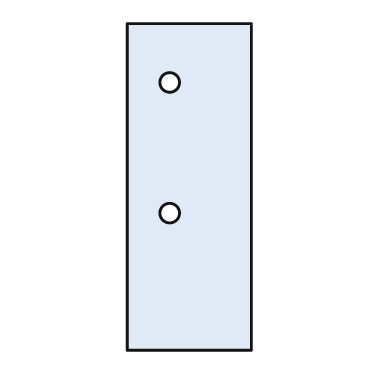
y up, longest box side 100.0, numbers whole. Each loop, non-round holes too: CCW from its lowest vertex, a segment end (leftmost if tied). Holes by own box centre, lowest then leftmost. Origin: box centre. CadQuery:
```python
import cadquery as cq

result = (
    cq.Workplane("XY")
    .moveTo(-19.0, -50.0)
    .lineTo(19.0, -50.0)
    .lineTo(19.0, 50.0)
    .lineTo(-19.0, 50.0)
    .close()
    .moveTo(-6.0, -8.0)
    .circle(3.0)
    .moveTo(-6.0, 32.0)
    .circle(3.0)
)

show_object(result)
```